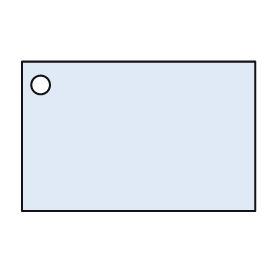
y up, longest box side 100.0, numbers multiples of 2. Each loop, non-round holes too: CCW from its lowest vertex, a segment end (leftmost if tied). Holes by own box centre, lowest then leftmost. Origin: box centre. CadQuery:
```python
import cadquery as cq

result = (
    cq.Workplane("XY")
    .moveTo(-50.0, -32.0)
    .lineTo(50.0, -32.0)
    .lineTo(50.0, 32.0)
    .lineTo(-50.0, 32.0)
    .close()
    .moveTo(-42.0, 22.0)
    .circle(4.0)
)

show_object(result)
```